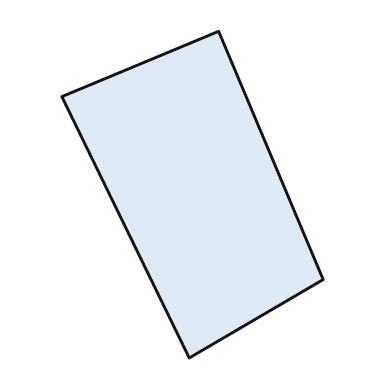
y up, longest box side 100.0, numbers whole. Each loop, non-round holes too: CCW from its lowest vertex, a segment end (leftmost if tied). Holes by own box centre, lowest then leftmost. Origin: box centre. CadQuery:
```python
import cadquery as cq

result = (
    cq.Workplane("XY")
    .moveTo(-1.0, -50.0)
    .lineTo(40.0, -26.0)
    .lineTo(8.0, 50.0)
    .lineTo(-40.0, 30.0)
    .close()
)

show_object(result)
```